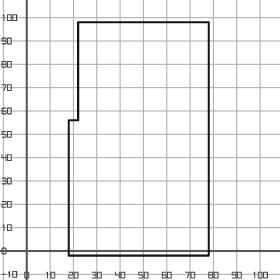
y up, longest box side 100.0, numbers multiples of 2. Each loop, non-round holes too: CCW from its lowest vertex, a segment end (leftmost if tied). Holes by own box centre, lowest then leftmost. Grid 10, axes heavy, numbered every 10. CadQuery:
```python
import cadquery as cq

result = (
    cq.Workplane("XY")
    .moveTo(18.0, -2.0)
    .lineTo(78.0, -2.0)
    .lineTo(78.0, 98.0)
    .lineTo(22.0, 98.0)
    .lineTo(22.0, 56.0)
    .lineTo(18.0, 56.0)
    .close()
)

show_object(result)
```